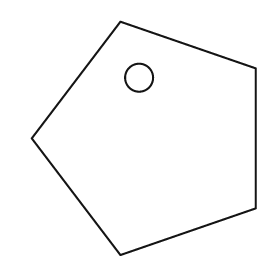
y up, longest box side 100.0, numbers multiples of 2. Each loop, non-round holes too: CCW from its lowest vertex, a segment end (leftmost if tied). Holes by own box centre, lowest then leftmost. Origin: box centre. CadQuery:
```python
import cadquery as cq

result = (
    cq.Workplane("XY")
    .moveTo(-10.0, -50.0)
    .lineTo(48.0, -30.0)
    .lineTo(48.0, 30.0)
    .lineTo(-10.0, 50.0)
    .lineTo(-48.0, 0.0)
    .close()
    .moveTo(-2.0, 26.0)
    .circle(6.0)
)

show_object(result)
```